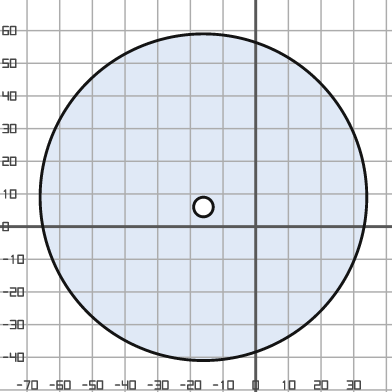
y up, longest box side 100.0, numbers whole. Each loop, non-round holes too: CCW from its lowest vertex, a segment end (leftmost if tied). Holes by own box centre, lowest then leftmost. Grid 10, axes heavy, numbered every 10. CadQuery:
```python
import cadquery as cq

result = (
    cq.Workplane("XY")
    .moveTo(-16.0, 9.0)
    .circle(50.0)
    .moveTo(-16.0, 6.0)
    .circle(3.0)
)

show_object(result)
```